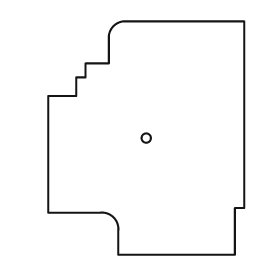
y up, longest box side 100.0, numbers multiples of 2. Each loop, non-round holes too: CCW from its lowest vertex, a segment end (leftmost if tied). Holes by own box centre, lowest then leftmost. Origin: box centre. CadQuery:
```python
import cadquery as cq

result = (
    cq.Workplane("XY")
    .moveTo(-12.0, -50.0)
    .lineTo(38.0, -50.0)
    .lineTo(38.0, -30.0)
    .lineTo(42.0, -30.0)
    .lineTo(42.0, 50.0)
    .lineTo(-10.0, 50.0)
    .threePointArc((-14.0, 48.0), (-16.0, 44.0))
    .lineTo(-16.0, 32.0)
    .lineTo(-26.0, 32.0)
    .lineTo(-26.0, 26.0)
    .lineTo(-30.0, 26.0)
    .lineTo(-30.0, 18.0)
    .lineTo(-42.0, 18.0)
    .lineTo(-42.0, -32.0)
    .lineTo(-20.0, -32.0)
    .threePointArc((-14.0, -34.0), (-12.0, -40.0))
    .close()
    .moveTo(0.0, 0.0)
    .circle(2.0)
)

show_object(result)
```